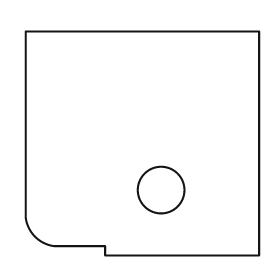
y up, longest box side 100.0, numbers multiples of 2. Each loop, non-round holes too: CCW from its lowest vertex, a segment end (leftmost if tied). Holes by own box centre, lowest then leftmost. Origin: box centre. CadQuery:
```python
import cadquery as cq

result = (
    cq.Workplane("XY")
    .moveTo(-16.0, -48.0)
    .lineTo(50.0, -48.0)
    .lineTo(50.0, 48.0)
    .lineTo(-50.0, 48.0)
    .lineTo(-50.0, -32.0)
    .threePointArc((-46.0, -40.0), (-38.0, -44.0))
    .lineTo(-16.0, -44.0)
    .close()
    .moveTo(8.0, -20.0)
    .circle(10.0)
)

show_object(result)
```